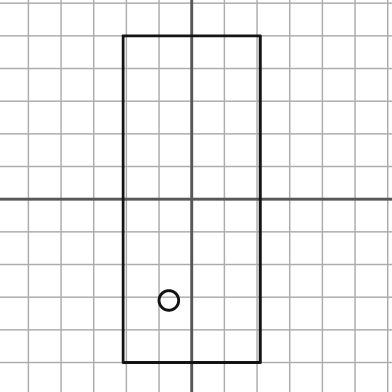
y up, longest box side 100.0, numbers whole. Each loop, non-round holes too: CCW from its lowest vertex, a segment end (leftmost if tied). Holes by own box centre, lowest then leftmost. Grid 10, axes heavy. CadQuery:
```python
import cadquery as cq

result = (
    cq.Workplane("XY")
    .moveTo(-21.0, -50.0)
    .lineTo(21.0, -50.0)
    .lineTo(21.0, 50.0)
    .lineTo(-21.0, 50.0)
    .close()
    .moveTo(-7.0, -31.0)
    .circle(3.0)
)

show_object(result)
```